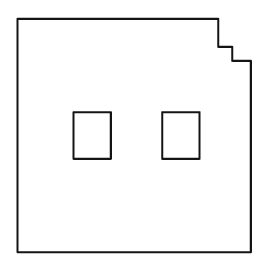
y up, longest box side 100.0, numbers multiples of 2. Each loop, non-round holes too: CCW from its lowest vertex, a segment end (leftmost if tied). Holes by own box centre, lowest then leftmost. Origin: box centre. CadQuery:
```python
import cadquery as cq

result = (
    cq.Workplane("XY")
    .moveTo(-50.0, -50.0)
    .lineTo(50.0, -50.0)
    .lineTo(50.0, 32.0)
    .lineTo(42.0, 32.0)
    .lineTo(42.0, 38.0)
    .lineTo(36.0, 38.0)
    .lineTo(36.0, 50.0)
    .lineTo(-50.0, 50.0)
    .close()
    .moveTo(-26.0, -10.0)
    .lineTo(-10.0, -10.0)
    .lineTo(-10.0, 10.0)
    .lineTo(-26.0, 10.0)
    .close()
    .moveTo(12.0, -10.0)
    .lineTo(28.0, -10.0)
    .lineTo(28.0, 10.0)
    .lineTo(12.0, 10.0)
    .close()
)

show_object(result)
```